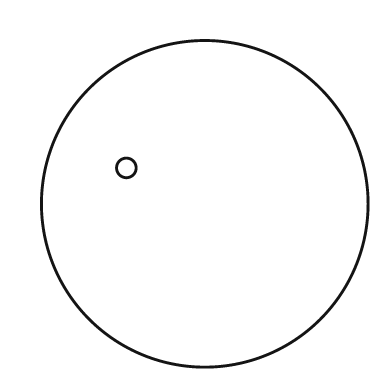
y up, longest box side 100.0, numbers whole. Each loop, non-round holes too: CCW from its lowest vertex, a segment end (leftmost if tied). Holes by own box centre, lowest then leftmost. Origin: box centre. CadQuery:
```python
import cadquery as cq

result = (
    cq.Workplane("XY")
    .moveTo(0.0, 0.0)
    .circle(50.0)
    .moveTo(-24.0, 11.0)
    .circle(3.0)
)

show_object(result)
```